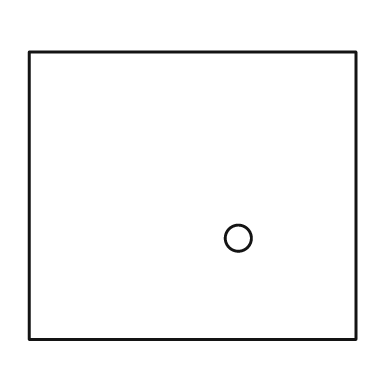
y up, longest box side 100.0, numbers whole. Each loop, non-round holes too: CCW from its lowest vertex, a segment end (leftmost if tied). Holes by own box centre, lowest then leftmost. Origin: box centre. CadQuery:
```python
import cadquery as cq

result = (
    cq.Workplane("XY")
    .moveTo(-50.0, -44.0)
    .lineTo(50.0, -44.0)
    .lineTo(50.0, 44.0)
    .lineTo(-50.0, 44.0)
    .close()
    .moveTo(14.0, -13.0)
    .circle(4.0)
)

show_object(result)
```